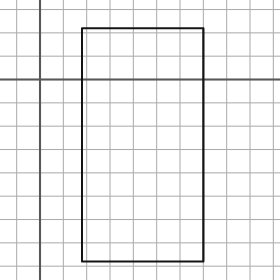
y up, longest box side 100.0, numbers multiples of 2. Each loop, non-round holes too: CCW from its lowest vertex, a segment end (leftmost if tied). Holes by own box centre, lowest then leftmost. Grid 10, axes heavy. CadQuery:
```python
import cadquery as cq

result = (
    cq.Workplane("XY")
    .moveTo(18.0, -78.0)
    .lineTo(70.0, -78.0)
    .lineTo(70.0, 22.0)
    .lineTo(18.0, 22.0)
    .close()
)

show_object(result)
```